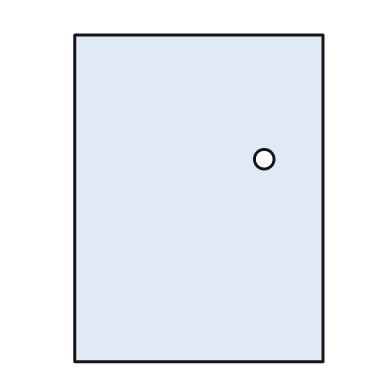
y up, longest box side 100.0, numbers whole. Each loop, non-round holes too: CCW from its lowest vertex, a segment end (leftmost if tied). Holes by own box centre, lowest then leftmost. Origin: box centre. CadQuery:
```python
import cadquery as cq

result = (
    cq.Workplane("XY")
    .moveTo(-38.0, -50.0)
    .lineTo(38.0, -50.0)
    .lineTo(38.0, 50.0)
    .lineTo(-38.0, 50.0)
    .close()
    .moveTo(20.0, 12.0)
    .circle(3.0)
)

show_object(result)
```